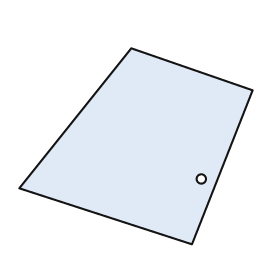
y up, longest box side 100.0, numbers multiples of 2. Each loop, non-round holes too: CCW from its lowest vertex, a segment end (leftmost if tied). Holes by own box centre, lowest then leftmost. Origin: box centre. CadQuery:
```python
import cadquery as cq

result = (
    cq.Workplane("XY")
    .moveTo(24.0, -42.0)
    .lineTo(50.0, 24.0)
    .lineTo(-2.0, 42.0)
    .lineTo(-50.0, -18.0)
    .close()
    .moveTo(28.0, -14.0)
    .circle(2.0)
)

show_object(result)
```